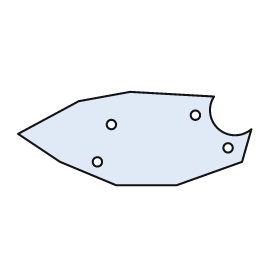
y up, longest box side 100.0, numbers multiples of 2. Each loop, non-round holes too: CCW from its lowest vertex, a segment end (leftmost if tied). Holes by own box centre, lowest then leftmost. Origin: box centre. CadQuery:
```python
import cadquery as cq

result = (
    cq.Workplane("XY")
    .moveTo(-8.0, -20.0)
    .lineTo(18.0, -20.0)
    .lineTo(46.0, -10.0)
    .lineTo(50.0, 4.0)
    .threePointArc((36.0, 4.0), (34.0, 18.0))
    .lineTo(-2.0, 20.0)
    .lineTo(-24.0, 16.0)
    .lineTo(-50.0, 2.0)
    .lineTo(-32.0, -10.0)
    .close()
    .moveTo(-16.0, -10.0)
    .circle(2.0)
    .moveTo(40.0, -4.0)
    .circle(2.0)
    .moveTo(-10.0, 6.0)
    .circle(2.0)
    .moveTo(26.0, 10.0)
    .circle(2.0)
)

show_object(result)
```